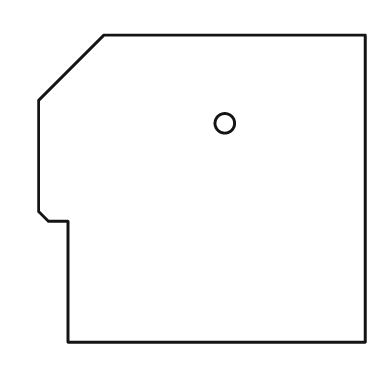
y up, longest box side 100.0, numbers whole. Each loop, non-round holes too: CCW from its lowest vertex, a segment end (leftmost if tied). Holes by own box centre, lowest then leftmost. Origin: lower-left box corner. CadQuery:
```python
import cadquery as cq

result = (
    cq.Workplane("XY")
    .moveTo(9.0, 0.0)
    .lineTo(100.0, 0.0)
    .lineTo(100.0, 94.0)
    .lineTo(20.0, 94.0)
    .lineTo(0.0, 74.0)
    .lineTo(0.0, 40.0)
    .lineTo(3.0, 37.0)
    .lineTo(9.0, 37.0)
    .close()
    .moveTo(57.0, 67.0)
    .circle(3.0)
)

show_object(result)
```